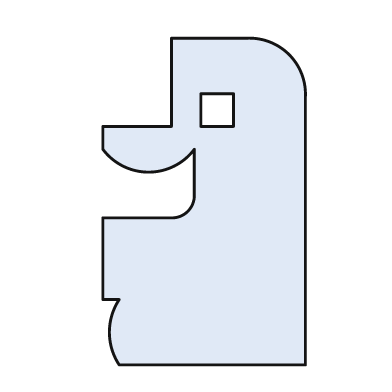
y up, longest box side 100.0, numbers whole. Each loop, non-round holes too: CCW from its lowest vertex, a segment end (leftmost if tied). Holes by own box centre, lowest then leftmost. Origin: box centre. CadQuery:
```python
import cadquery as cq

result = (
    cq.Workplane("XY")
    .moveTo(-26.0, -50.0)
    .lineTo(31.0, -50.0)
    .lineTo(31.0, 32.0)
    .threePointArc((26.0, 45.0), (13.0, 50.0))
    .lineTo(-10.0, 50.0)
    .lineTo(-10.0, 23.0)
    .lineTo(-31.0, 23.0)
    .lineTo(-31.0, 16.0)
    .threePointArc((-17.0, 9.0), (-3.0, 16.0))
    .lineTo(-3.0, 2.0)
    .threePointArc((-5.0, -3.0), (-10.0, -5.0))
    .lineTo(-31.0, -5.0)
    .lineTo(-31.0, -30.0)
    .lineTo(-26.0, -30.0)
    .threePointArc((-29.0, -40.0), (-26.0, -50.0))
    .close()
    .moveTo(-1.0, 23.0)
    .lineTo(9.0, 23.0)
    .lineTo(9.0, 33.0)
    .lineTo(-1.0, 33.0)
    .close()
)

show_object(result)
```